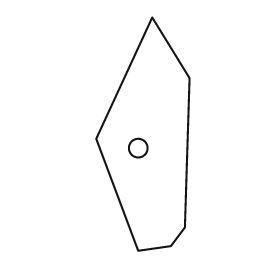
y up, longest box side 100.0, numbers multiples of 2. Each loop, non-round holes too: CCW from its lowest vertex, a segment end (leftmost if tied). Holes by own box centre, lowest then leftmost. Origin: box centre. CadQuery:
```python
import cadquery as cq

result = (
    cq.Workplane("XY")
    .moveTo(-2.0, -50.0)
    .lineTo(12.0, -48.0)
    .lineTo(18.0, -40.0)
    .lineTo(20.0, 24.0)
    .lineTo(4.0, 50.0)
    .lineTo(-20.0, -2.0)
    .close()
    .moveTo(-2.0, -6.0)
    .circle(4.0)
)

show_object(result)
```